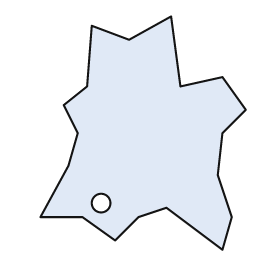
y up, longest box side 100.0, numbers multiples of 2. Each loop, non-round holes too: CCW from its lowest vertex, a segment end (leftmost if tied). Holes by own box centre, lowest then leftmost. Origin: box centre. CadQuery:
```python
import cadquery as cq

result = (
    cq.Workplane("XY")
    .moveTo(34.0, -50.0)
    .lineTo(38.0, -36.0)
    .lineTo(32.0, -18.0)
    .lineTo(34.0, 0.0)
    .lineTo(44.0, 10.0)
    .lineTo(34.0, 24.0)
    .lineTo(16.0, 20.0)
    .lineTo(12.0, 50.0)
    .lineTo(-6.0, 40.0)
    .lineTo(-22.0, 46.0)
    .lineTo(-24.0, 20.0)
    .lineTo(-34.0, 12.0)
    .lineTo(-28.0, 0.0)
    .lineTo(-32.0, -14.0)
    .lineTo(-44.0, -36.0)
    .lineTo(-26.0, -36.0)
    .lineTo(-12.0, -46.0)
    .lineTo(-2.0, -36.0)
    .lineTo(10.0, -32.0)
    .close()
    .moveTo(-18.0, -30.0)
    .circle(4.0)
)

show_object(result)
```